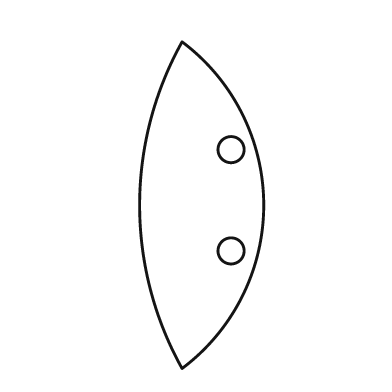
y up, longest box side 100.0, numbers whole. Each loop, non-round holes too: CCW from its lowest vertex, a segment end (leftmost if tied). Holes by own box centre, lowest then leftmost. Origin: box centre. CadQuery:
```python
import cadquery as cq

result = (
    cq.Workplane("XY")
    .moveTo(-6.0, -50.0)
    .threePointArc((19.0, 0.0), (-6.0, 50.0))
    .threePointArc((-19.0, 0.0), (-6.0, -50.0))
    .close()
    .moveTo(9.0, -14.0)
    .circle(4.0)
    .moveTo(9.0, 17.0)
    .circle(4.0)
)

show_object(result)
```